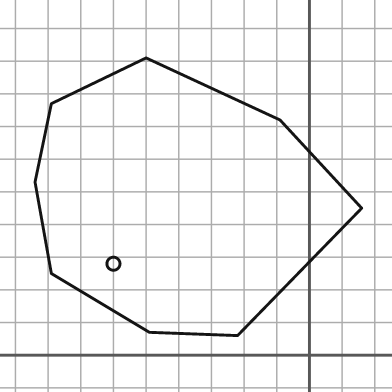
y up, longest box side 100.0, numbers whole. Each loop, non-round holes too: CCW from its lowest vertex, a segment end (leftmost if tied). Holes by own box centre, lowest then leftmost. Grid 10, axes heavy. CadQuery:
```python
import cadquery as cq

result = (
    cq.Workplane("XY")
    .moveTo(-22.0, 6.0)
    .lineTo(16.0, 45.0)
    .lineTo(-9.0, 72.0)
    .lineTo(-50.0, 91.0)
    .lineTo(-79.0, 77.0)
    .lineTo(-84.0, 53.0)
    .lineTo(-79.0, 25.0)
    .lineTo(-49.0, 7.0)
    .close()
    .moveTo(-60.0, 28.0)
    .circle(2.0)
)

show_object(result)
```